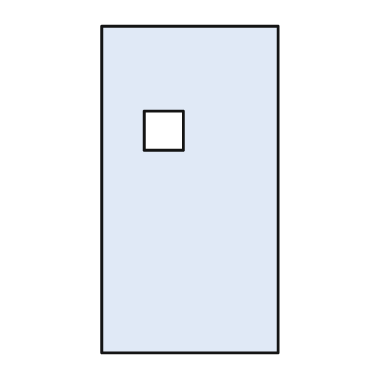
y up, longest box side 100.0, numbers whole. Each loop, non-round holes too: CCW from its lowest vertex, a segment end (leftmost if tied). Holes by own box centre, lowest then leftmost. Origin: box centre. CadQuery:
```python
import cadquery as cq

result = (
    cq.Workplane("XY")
    .moveTo(-27.0, -50.0)
    .lineTo(27.0, -50.0)
    .lineTo(27.0, 50.0)
    .lineTo(-27.0, 50.0)
    .close()
    .moveTo(-14.0, 12.0)
    .lineTo(-2.0, 12.0)
    .lineTo(-2.0, 24.0)
    .lineTo(-14.0, 24.0)
    .close()
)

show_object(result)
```